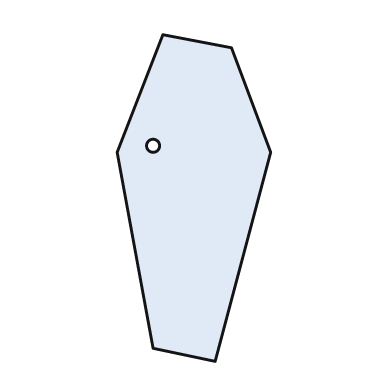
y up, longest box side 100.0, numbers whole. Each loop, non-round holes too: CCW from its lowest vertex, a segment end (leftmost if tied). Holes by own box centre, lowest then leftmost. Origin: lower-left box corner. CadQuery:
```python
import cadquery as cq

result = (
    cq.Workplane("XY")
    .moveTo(30.0, 0.0)
    .lineTo(47.0, 64.0)
    .lineTo(35.0, 96.0)
    .lineTo(14.0, 100.0)
    .lineTo(0.0, 64.0)
    .lineTo(11.0, 4.0)
    .close()
    .moveTo(11.0, 66.0)
    .circle(2.0)
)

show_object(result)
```